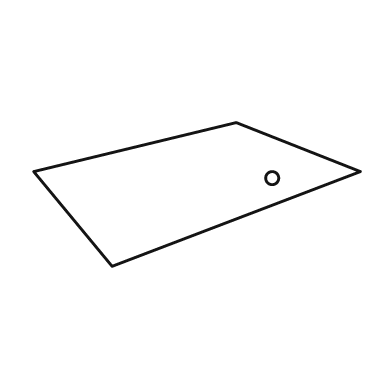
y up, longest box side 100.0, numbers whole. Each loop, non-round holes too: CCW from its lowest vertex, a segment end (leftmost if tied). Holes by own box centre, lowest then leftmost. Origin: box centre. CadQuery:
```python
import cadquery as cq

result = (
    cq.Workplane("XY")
    .moveTo(-26.0, -22.0)
    .lineTo(50.0, 7.0)
    .lineTo(12.0, 22.0)
    .lineTo(-50.0, 7.0)
    .close()
    .moveTo(23.0, 5.0)
    .circle(2.0)
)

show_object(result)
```